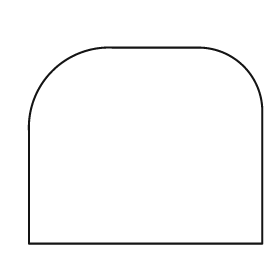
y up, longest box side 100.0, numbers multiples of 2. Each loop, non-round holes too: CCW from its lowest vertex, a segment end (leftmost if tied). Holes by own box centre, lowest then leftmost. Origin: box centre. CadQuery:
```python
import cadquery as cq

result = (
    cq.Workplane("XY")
    .moveTo(-50.0, -42.0)
    .lineTo(50.0, -42.0)
    .lineTo(50.0, 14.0)
    .threePointArc((42.0, 34.0), (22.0, 42.0))
    .lineTo(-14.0, 42.0)
    .threePointArc((-40.0, 32.0), (-50.0, 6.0))
    .close()
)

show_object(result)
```